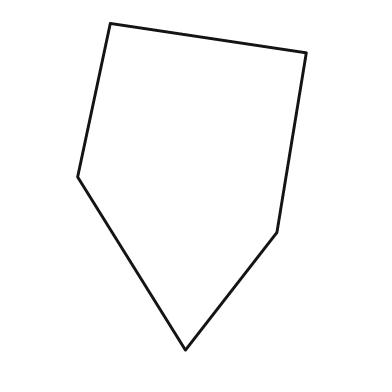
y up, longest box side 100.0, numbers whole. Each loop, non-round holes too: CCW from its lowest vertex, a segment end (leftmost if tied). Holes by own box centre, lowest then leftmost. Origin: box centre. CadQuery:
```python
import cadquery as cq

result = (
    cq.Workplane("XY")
    .moveTo(-2.0, -50.0)
    .lineTo(26.0, -14.0)
    .lineTo(35.0, 41.0)
    .lineTo(-25.0, 50.0)
    .lineTo(-35.0, 3.0)
    .close()
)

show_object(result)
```